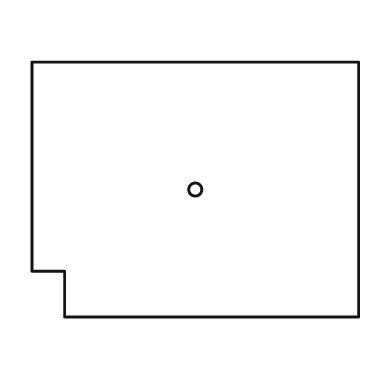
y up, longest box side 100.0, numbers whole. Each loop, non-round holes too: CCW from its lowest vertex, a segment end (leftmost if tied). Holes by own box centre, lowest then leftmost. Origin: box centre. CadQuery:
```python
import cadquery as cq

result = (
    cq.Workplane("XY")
    .moveTo(-40.0, -39.0)
    .lineTo(50.0, -39.0)
    .lineTo(50.0, 39.0)
    .lineTo(-50.0, 39.0)
    .lineTo(-50.0, -25.0)
    .lineTo(-40.0, -25.0)
    .close()
    .moveTo(0.0, 0.0)
    .circle(2.0)
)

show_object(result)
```